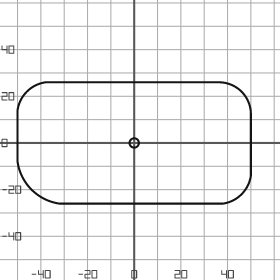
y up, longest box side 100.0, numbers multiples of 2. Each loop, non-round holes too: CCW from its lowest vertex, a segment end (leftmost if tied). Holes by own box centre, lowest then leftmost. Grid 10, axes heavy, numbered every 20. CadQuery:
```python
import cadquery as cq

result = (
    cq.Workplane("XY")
    .moveTo(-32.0, -26.0)
    .lineTo(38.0, -26.0)
    .threePointArc((46.0, -22.0), (50.0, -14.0))
    .lineTo(50.0, 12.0)
    .threePointArc((46.0, 22.0), (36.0, 26.0))
    .lineTo(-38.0, 26.0)
    .threePointArc((-46.0, 22.0), (-50.0, 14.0))
    .lineTo(-50.0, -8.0)
    .threePointArc((-44.0, -20.0), (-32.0, -26.0))
    .close()
    .moveTo(0.0, 0.0)
    .circle(2.0)
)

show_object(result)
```